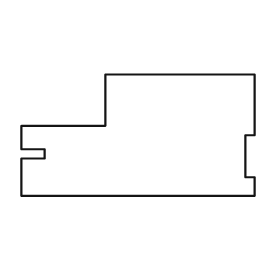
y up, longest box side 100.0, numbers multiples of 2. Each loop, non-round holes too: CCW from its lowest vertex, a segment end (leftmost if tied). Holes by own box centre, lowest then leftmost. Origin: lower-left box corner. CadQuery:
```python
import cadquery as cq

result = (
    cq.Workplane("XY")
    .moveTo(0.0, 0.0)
    .lineTo(100.0, 0.0)
    .lineTo(100.0, 8.0)
    .lineTo(96.0, 8.0)
    .lineTo(96.0, 26.0)
    .lineTo(100.0, 26.0)
    .lineTo(100.0, 52.0)
    .lineTo(36.0, 52.0)
    .lineTo(36.0, 30.0)
    .lineTo(0.0, 30.0)
    .lineTo(0.0, 20.0)
    .lineTo(10.0, 20.0)
    .lineTo(10.0, 16.0)
    .lineTo(0.0, 16.0)
    .close()
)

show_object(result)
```